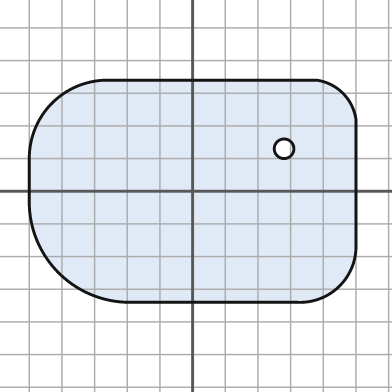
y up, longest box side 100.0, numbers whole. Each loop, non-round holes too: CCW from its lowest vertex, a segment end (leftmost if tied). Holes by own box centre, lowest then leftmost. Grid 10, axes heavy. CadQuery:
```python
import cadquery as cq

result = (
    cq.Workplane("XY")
    .moveTo(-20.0, -34.0)
    .lineTo(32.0, -34.0)
    .threePointArc((45.0, -29.0), (50.0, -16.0))
    .lineTo(50.0, 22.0)
    .threePointArc((46.0, 30.0), (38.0, 34.0))
    .lineTo(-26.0, 34.0)
    .threePointArc((-43.0, 27.0), (-50.0, 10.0))
    .lineTo(-50.0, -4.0)
    .threePointArc((-41.0, -25.0), (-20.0, -34.0))
    .close()
    .moveTo(28.0, 13.0)
    .circle(3.0)
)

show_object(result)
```